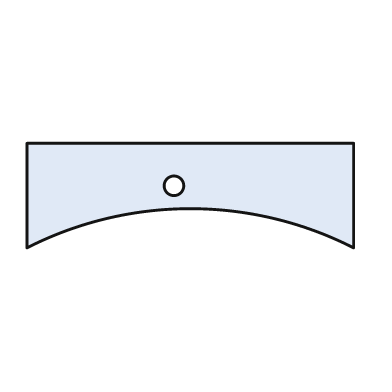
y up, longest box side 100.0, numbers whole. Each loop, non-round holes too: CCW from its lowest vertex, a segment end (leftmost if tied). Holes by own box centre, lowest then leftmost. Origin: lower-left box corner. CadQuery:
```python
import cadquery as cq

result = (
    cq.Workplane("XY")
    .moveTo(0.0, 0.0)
    .threePointArc((50.0, 12.0), (100.0, 0.0))
    .lineTo(100.0, 32.0)
    .lineTo(0.0, 32.0)
    .close()
    .moveTo(45.0, 19.0)
    .circle(3.0)
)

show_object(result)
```